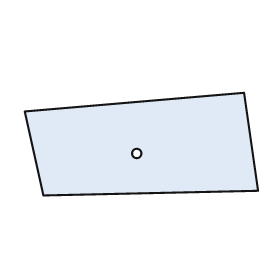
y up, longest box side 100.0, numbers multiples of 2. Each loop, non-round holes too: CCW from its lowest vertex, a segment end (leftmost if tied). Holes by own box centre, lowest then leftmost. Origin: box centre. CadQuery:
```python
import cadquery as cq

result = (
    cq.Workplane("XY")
    .moveTo(-42.0, -22.0)
    .lineTo(50.0, -20.0)
    .lineTo(44.0, 22.0)
    .lineTo(-50.0, 14.0)
    .close()
    .moveTo(-2.0, -4.0)
    .circle(2.0)
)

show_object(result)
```